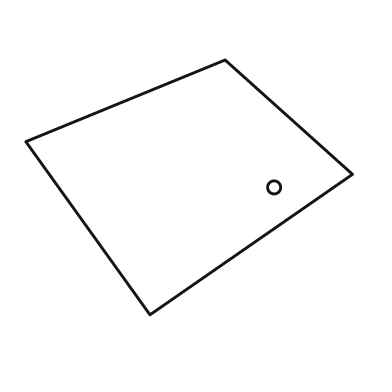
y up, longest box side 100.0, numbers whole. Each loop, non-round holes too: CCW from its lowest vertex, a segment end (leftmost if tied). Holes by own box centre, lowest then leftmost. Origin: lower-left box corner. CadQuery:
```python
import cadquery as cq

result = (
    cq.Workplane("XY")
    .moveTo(38.0, 0.0)
    .lineTo(100.0, 43.0)
    .lineTo(61.0, 78.0)
    .lineTo(0.0, 53.0)
    .close()
    .moveTo(76.0, 39.0)
    .circle(2.0)
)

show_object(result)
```